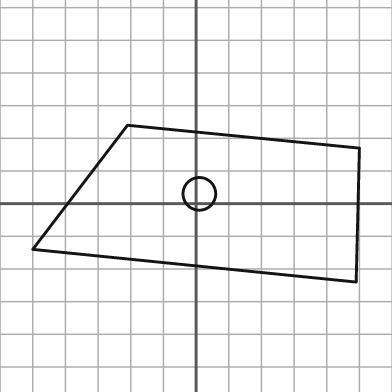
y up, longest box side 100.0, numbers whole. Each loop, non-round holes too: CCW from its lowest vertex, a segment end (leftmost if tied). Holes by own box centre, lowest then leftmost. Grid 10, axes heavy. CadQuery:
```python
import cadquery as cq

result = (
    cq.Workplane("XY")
    .moveTo(49.0, -24.0)
    .lineTo(50.0, 17.0)
    .lineTo(-21.0, 24.0)
    .lineTo(-50.0, -14.0)
    .close()
    .moveTo(1.0, 3.0)
    .circle(5.0)
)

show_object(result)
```